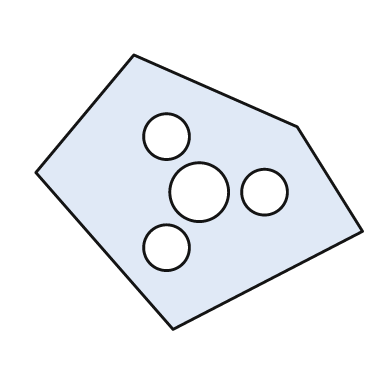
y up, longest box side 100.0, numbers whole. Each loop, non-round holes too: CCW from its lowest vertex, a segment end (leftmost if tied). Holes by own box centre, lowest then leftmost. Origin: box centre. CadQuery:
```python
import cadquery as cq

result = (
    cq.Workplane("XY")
    .moveTo(-8.0, -42.0)
    .lineTo(50.0, -12.0)
    .lineTo(30.0, 20.0)
    .lineTo(-20.0, 42.0)
    .lineTo(-50.0, 6.0)
    .close()
    .moveTo(-10.0, -17.0)
    .circle(7.0)
    .moveTo(0.0, 0.0)
    .circle(9.0)
    .moveTo(20.0, 0.0)
    .circle(7.0)
    .moveTo(-10.0, 17.0)
    .circle(7.0)
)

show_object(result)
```